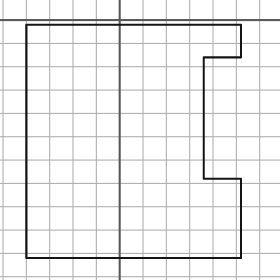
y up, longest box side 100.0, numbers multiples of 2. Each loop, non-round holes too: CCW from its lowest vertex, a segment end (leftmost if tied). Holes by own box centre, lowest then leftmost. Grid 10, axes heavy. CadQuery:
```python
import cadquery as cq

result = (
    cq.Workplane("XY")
    .moveTo(-40.0, -102.0)
    .lineTo(52.0, -102.0)
    .lineTo(52.0, -68.0)
    .lineTo(36.0, -68.0)
    .lineTo(36.0, -16.0)
    .lineTo(52.0, -16.0)
    .lineTo(52.0, -2.0)
    .lineTo(-40.0, -2.0)
    .close()
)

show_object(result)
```